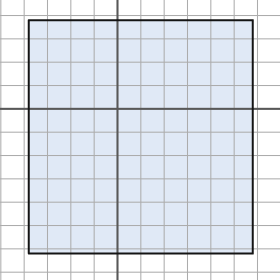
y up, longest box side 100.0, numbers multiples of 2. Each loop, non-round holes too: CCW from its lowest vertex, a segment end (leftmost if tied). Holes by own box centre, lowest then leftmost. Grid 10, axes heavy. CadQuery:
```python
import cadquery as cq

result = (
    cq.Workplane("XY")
    .moveTo(-38.0, -62.0)
    .lineTo(58.0, -62.0)
    .lineTo(58.0, 38.0)
    .lineTo(-38.0, 38.0)
    .close()
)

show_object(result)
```